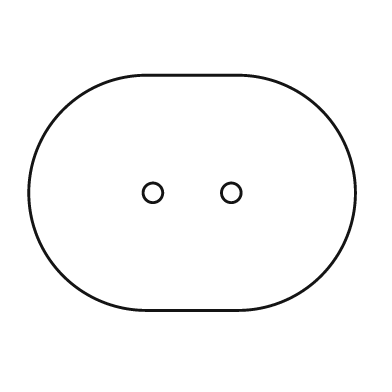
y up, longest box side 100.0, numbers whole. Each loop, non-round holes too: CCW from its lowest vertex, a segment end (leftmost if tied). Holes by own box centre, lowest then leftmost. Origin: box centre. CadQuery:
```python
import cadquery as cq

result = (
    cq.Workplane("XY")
    .moveTo(-14.0, -36.0)
    .lineTo(14.0, -36.0)
    .threePointArc((50.0, 0.0), (14.0, 36.0))
    .lineTo(-14.0, 36.0)
    .threePointArc((-50.0, 0.0), (-14.0, -36.0))
    .close()
    .moveTo(-12.0, 0.0)
    .circle(3.0)
    .moveTo(12.0, 0.0)
    .circle(3.0)
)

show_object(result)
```